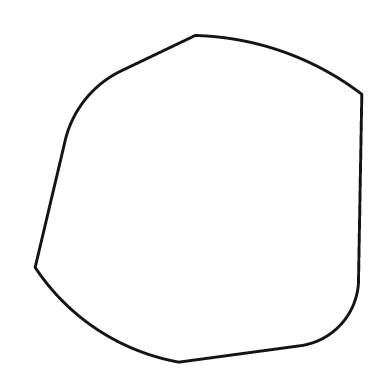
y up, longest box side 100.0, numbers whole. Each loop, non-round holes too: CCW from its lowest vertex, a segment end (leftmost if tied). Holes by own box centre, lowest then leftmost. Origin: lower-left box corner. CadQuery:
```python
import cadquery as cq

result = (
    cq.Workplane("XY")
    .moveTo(44.0, 0.0)
    .lineTo(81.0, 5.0)
    .threePointArc((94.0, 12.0), (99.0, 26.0))
    .lineTo(100.0, 82.0)
    .threePointArc((76.0, 95.0), (49.0, 100.0))
    .lineTo(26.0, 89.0)
    .threePointArc((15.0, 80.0), (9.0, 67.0))
    .lineTo(0.0, 29.0)
    .threePointArc((19.0, 10.0), (44.0, 0.0))
    .close()
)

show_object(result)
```